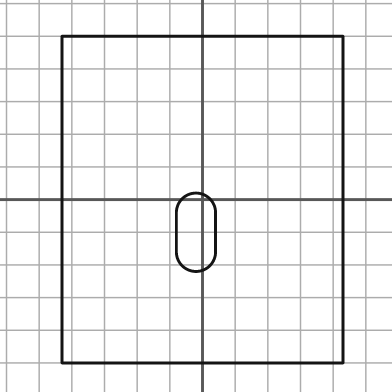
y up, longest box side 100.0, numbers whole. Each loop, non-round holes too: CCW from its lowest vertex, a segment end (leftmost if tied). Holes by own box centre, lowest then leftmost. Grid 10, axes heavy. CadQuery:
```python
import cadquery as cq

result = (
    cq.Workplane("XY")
    .moveTo(-43.0, -50.0)
    .lineTo(43.0, -50.0)
    .lineTo(43.0, 50.0)
    .lineTo(-43.0, 50.0)
    .close()
    .moveTo(-8.0, -16.0)
    .threePointArc((-2.0, -22.0), (4.0, -16.0))
    .lineTo(4.0, -4.0)
    .threePointArc((-2.0, 2.0), (-8.0, -4.0))
    .close()
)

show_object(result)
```